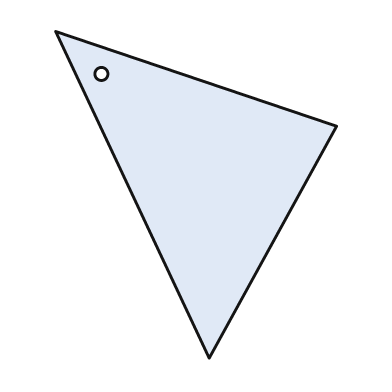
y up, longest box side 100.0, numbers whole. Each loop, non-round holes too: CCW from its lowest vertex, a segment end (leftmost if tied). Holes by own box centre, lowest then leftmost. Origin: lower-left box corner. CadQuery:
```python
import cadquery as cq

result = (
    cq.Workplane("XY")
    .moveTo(47.0, 0.0)
    .lineTo(86.0, 71.0)
    .lineTo(0.0, 100.0)
    .close()
    .moveTo(14.0, 87.0)
    .circle(2.0)
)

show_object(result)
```